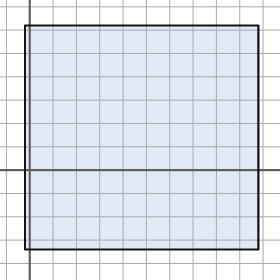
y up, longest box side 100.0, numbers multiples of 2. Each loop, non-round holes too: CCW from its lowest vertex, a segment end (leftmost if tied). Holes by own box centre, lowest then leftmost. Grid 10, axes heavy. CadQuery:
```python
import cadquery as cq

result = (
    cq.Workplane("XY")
    .moveTo(-2.0, -34.0)
    .lineTo(98.0, -34.0)
    .lineTo(98.0, 62.0)
    .lineTo(-2.0, 62.0)
    .close()
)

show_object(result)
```